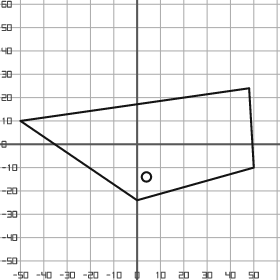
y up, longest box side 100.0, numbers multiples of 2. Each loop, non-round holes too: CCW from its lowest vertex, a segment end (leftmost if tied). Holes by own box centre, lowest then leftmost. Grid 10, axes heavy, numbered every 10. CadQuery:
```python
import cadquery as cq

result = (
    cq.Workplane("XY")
    .moveTo(0.0, -24.0)
    .lineTo(50.0, -10.0)
    .lineTo(48.0, 24.0)
    .lineTo(-50.0, 10.0)
    .close()
    .moveTo(4.0, -14.0)
    .circle(2.0)
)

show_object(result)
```